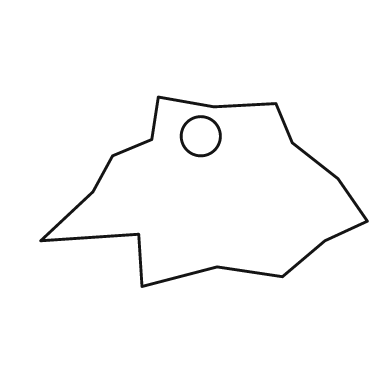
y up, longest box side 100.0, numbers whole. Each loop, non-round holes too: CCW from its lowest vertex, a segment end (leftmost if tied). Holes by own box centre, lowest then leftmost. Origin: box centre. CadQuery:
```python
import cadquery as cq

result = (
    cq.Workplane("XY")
    .moveTo(-19.0, -29.0)
    .lineTo(4.0, -23.0)
    .lineTo(24.0, -26.0)
    .lineTo(37.0, -15.0)
    .lineTo(50.0, -9.0)
    .lineTo(41.0, 4.0)
    .lineTo(27.0, 15.0)
    .lineTo(22.0, 27.0)
    .lineTo(3.0, 26.0)
    .lineTo(-14.0, 29.0)
    .lineTo(-16.0, 16.0)
    .lineTo(-28.0, 11.0)
    .lineTo(-34.0, 0.0)
    .lineTo(-50.0, -15.0)
    .lineTo(-20.0, -13.0)
    .close()
    .moveTo(-1.0, 17.0)
    .circle(6.0)
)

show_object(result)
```